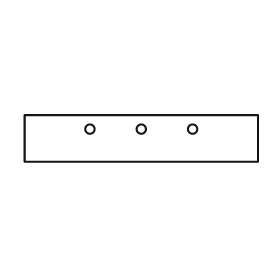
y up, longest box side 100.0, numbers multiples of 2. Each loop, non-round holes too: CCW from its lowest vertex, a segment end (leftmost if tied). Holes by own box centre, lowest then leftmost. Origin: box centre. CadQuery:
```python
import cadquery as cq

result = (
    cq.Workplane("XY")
    .moveTo(-50.0, -10.0)
    .lineTo(50.0, -10.0)
    .lineTo(50.0, 10.0)
    .lineTo(-50.0, 10.0)
    .close()
    .moveTo(-22.0, 4.0)
    .circle(2.0)
    .moveTo(0.0, 4.0)
    .circle(2.0)
    .moveTo(22.0, 4.0)
    .circle(2.0)
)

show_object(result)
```